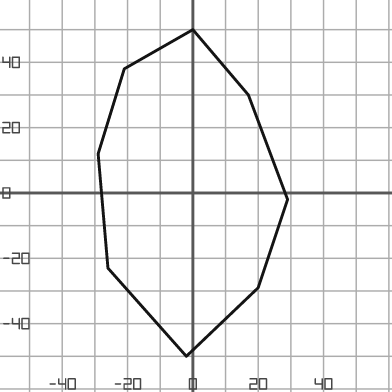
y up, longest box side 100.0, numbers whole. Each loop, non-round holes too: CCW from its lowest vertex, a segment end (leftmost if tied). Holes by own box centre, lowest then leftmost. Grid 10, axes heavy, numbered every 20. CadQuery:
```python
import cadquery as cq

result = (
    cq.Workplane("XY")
    .moveTo(-2.0, -50.0)
    .lineTo(20.0, -29.0)
    .lineTo(29.0, -2.0)
    .lineTo(17.0, 30.0)
    .lineTo(0.0, 50.0)
    .lineTo(-21.0, 38.0)
    .lineTo(-29.0, 12.0)
    .lineTo(-26.0, -23.0)
    .close()
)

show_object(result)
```